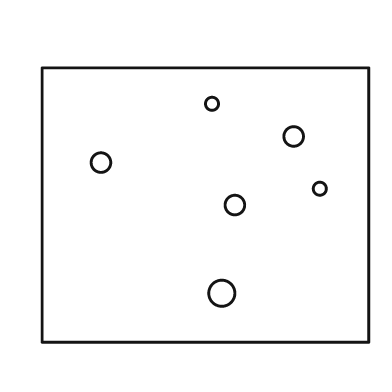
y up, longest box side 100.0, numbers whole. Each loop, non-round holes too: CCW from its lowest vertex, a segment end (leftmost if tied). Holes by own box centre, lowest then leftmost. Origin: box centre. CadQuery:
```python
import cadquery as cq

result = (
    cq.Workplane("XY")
    .moveTo(-50.0, -42.0)
    .lineTo(50.0, -42.0)
    .lineTo(50.0, 42.0)
    .lineTo(-50.0, 42.0)
    .close()
    .moveTo(5.0, -27.0)
    .circle(4.0)
    .moveTo(9.0, 0.0)
    .circle(3.0)
    .moveTo(35.0, 5.0)
    .circle(2.0)
    .moveTo(-32.0, 13.0)
    .circle(3.0)
    .moveTo(27.0, 21.0)
    .circle(3.0)
    .moveTo(2.0, 31.0)
    .circle(2.0)
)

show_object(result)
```